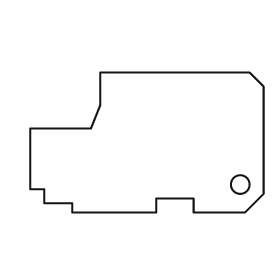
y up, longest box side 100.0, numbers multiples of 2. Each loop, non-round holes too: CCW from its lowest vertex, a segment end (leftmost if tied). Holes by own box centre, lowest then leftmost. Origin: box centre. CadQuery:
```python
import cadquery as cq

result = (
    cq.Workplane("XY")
    .moveTo(-32.0, -30.0)
    .lineTo(4.0, -30.0)
    .lineTo(4.0, -24.0)
    .lineTo(20.0, -24.0)
    .lineTo(20.0, -30.0)
    .lineTo(42.0, -30.0)
    .lineTo(50.0, -22.0)
    .lineTo(50.0, 24.0)
    .lineTo(44.0, 30.0)
    .lineTo(-20.0, 30.0)
    .lineTo(-20.0, 16.0)
    .lineTo(-24.0, 6.0)
    .lineTo(-50.0, 6.0)
    .lineTo(-50.0, -20.0)
    .lineTo(-44.0, -20.0)
    .lineTo(-44.0, -26.0)
    .lineTo(-32.0, -26.0)
    .close()
    .moveTo(40.0, -18.0)
    .circle(4.0)
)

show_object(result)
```